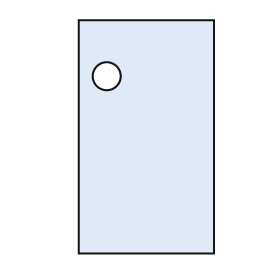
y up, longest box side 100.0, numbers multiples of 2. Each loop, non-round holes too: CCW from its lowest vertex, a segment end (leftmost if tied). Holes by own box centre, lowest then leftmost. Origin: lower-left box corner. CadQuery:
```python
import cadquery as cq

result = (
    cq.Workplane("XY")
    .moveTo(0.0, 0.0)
    .lineTo(58.0, 0.0)
    .lineTo(58.0, 100.0)
    .lineTo(0.0, 100.0)
    .close()
    .moveTo(12.0, 76.0)
    .circle(6.0)
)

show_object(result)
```